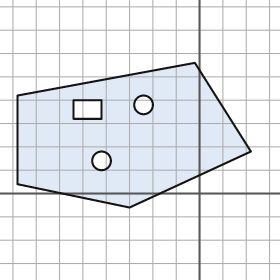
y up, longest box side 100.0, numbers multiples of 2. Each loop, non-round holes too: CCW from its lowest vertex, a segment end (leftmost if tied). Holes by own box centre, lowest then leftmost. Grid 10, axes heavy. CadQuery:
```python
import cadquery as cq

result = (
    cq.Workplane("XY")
    .moveTo(-30.0, -6.0)
    .lineTo(22.0, 18.0)
    .lineTo(-2.0, 56.0)
    .lineTo(-78.0, 42.0)
    .lineTo(-78.0, 4.0)
    .close()
    .moveTo(-42.0, 14.0)
    .circle(4.0)
    .moveTo(-54.0, 32.0)
    .lineTo(-42.0, 32.0)
    .lineTo(-42.0, 40.0)
    .lineTo(-54.0, 40.0)
    .close()
    .moveTo(-24.0, 38.0)
    .circle(4.0)
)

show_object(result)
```